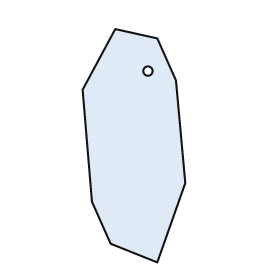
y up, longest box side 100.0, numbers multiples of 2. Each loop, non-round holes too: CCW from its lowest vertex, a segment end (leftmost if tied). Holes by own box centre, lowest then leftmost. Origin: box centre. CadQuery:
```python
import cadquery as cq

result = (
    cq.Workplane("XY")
    .moveTo(10.0, -50.0)
    .lineTo(22.0, -16.0)
    .lineTo(18.0, 28.0)
    .lineTo(10.0, 46.0)
    .lineTo(-8.0, 50.0)
    .lineTo(-22.0, 24.0)
    .lineTo(-18.0, -24.0)
    .lineTo(-10.0, -42.0)
    .close()
    .moveTo(6.0, 32.0)
    .circle(2.0)
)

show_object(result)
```